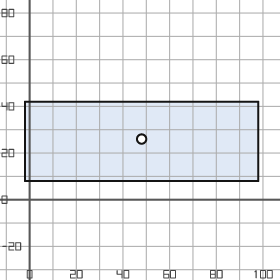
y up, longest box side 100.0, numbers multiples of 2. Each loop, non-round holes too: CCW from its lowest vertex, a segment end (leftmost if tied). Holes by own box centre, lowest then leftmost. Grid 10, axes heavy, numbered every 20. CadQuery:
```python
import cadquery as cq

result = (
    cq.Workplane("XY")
    .moveTo(-2.0, 8.0)
    .lineTo(98.0, 8.0)
    .lineTo(98.0, 42.0)
    .lineTo(-2.0, 42.0)
    .close()
    .moveTo(48.0, 26.0)
    .circle(2.0)
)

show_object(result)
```